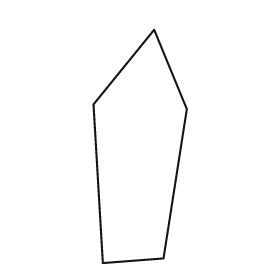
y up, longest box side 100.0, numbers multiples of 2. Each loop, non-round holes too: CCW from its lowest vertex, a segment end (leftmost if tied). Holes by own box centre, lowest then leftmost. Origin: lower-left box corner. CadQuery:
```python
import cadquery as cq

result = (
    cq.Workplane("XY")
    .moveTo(4.0, 0.0)
    .lineTo(30.0, 2.0)
    .lineTo(40.0, 66.0)
    .lineTo(26.0, 100.0)
    .lineTo(0.0, 68.0)
    .close()
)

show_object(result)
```